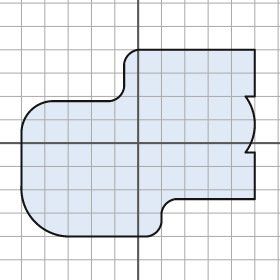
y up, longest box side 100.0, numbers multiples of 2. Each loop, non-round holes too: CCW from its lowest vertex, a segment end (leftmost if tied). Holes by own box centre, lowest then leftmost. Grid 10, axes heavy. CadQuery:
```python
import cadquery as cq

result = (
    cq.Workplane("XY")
    .moveTo(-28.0, -40.0)
    .lineTo(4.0, -40.0)
    .threePointArc((8.0, -38.0), (10.0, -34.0))
    .lineTo(10.0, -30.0)
    .threePointArc((12.0, -26.0), (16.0, -24.0))
    .lineTo(50.0, -24.0)
    .lineTo(50.0, -4.0)
    .lineTo(46.0, -4.0)
    .threePointArc((50.0, 8.0), (46.0, 20.0))
    .lineTo(50.0, 20.0)
    .lineTo(50.0, 40.0)
    .lineTo(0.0, 40.0)
    .threePointArc((-4.0, 38.0), (-6.0, 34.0))
    .lineTo(-6.0, 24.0)
    .threePointArc((-8.0, 20.0), (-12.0, 18.0))
    .lineTo(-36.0, 18.0)
    .threePointArc((-46.0, 14.0), (-50.0, 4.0))
    .lineTo(-50.0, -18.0)
    .threePointArc((-44.0, -34.0), (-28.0, -40.0))
    .close()
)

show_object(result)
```